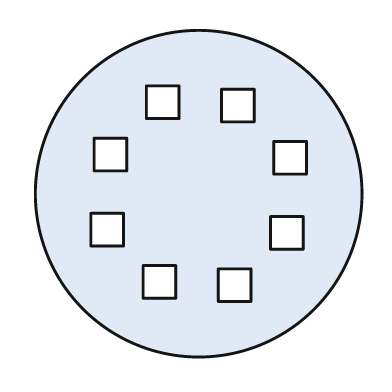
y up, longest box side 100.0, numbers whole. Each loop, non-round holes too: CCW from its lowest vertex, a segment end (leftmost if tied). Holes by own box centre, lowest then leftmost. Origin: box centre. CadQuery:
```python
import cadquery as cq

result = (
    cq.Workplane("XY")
    .moveTo(0.0, 0.0)
    .circle(50.0)
    .moveTo(6.0, -33.0)
    .lineTo(16.0, -33.0)
    .lineTo(16.0, -23.0)
    .lineTo(6.0, -23.0)
    .close()
    .moveTo(-17.0, -32.0)
    .lineTo(-7.0, -32.0)
    .lineTo(-7.0, -22.0)
    .lineTo(-17.0, -22.0)
    .close()
    .moveTo(22.0, -17.0)
    .lineTo(32.0, -17.0)
    .lineTo(32.0, -7.0)
    .lineTo(22.0, -7.0)
    .close()
    .moveTo(-33.0, -16.0)
    .lineTo(-23.0, -16.0)
    .lineTo(-23.0, -6.0)
    .lineTo(-33.0, -6.0)
    .close()
    .moveTo(23.0, 6.0)
    .lineTo(33.0, 6.0)
    .lineTo(33.0, 16.0)
    .lineTo(23.0, 16.0)
    .close()
    .moveTo(-32.0, 7.0)
    .lineTo(-22.0, 7.0)
    .lineTo(-22.0, 17.0)
    .lineTo(-32.0, 17.0)
    .close()
    .moveTo(7.0, 22.0)
    .lineTo(17.0, 22.0)
    .lineTo(17.0, 32.0)
    .lineTo(7.0, 32.0)
    .close()
    .moveTo(-16.0, 23.0)
    .lineTo(-6.0, 23.0)
    .lineTo(-6.0, 33.0)
    .lineTo(-16.0, 33.0)
    .close()
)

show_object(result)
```